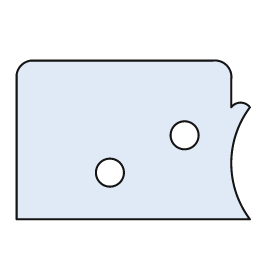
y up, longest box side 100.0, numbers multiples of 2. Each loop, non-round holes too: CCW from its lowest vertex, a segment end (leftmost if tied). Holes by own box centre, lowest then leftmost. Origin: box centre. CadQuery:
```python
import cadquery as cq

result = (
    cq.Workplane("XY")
    .moveTo(-50.0, -34.0)
    .lineTo(50.0, -34.0)
    .threePointArc((42.0, -10.0), (50.0, 14.0))
    .threePointArc((46.0, 16.0), (42.0, 14.0))
    .lineTo(42.0, 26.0)
    .threePointArc((40.0, 32.0), (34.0, 34.0))
    .lineTo(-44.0, 34.0)
    .threePointArc((-48.0, 32.0), (-50.0, 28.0))
    .close()
    .moveTo(-10.0, -14.0)
    .circle(6.0)
    .moveTo(22.0, 2.0)
    .circle(6.0)
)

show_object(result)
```